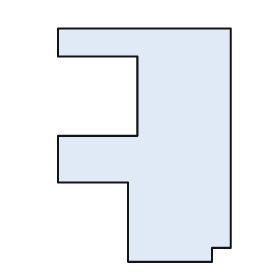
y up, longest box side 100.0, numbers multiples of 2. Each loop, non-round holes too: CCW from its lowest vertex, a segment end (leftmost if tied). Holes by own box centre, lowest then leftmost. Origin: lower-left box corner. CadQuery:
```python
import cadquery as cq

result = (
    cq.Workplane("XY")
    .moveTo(30.0, 0.0)
    .lineTo(66.0, 0.0)
    .lineTo(66.0, 6.0)
    .lineTo(74.0, 6.0)
    .lineTo(74.0, 100.0)
    .lineTo(0.0, 100.0)
    .lineTo(0.0, 88.0)
    .lineTo(34.0, 88.0)
    .lineTo(34.0, 54.0)
    .lineTo(0.0, 54.0)
    .lineTo(0.0, 34.0)
    .lineTo(30.0, 34.0)
    .close()
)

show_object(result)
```